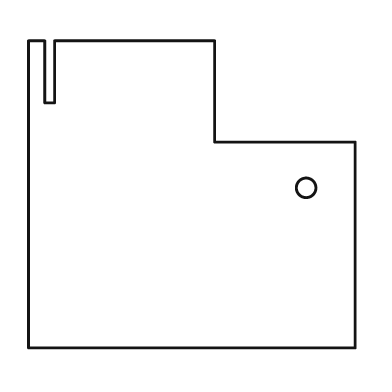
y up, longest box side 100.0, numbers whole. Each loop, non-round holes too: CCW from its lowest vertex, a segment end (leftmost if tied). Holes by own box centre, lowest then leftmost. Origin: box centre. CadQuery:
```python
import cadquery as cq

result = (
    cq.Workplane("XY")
    .moveTo(-50.0, -47.0)
    .lineTo(50.0, -47.0)
    .lineTo(50.0, 16.0)
    .lineTo(7.0, 16.0)
    .lineTo(7.0, 47.0)
    .lineTo(-42.0, 47.0)
    .lineTo(-42.0, 28.0)
    .lineTo(-45.0, 28.0)
    .lineTo(-45.0, 47.0)
    .lineTo(-50.0, 47.0)
    .close()
    .moveTo(35.0, 2.0)
    .circle(3.0)
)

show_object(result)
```